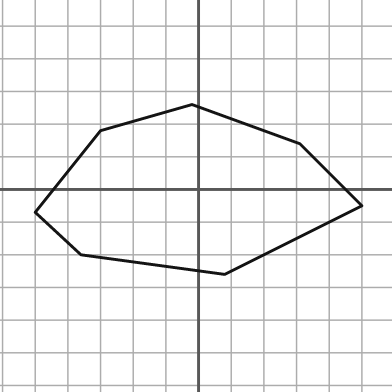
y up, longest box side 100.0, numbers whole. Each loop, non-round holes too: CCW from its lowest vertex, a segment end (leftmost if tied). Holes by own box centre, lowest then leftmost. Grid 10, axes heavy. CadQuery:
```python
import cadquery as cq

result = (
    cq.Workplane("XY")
    .moveTo(8.0, -26.0)
    .lineTo(50.0, -5.0)
    .lineTo(31.0, 14.0)
    .lineTo(-2.0, 26.0)
    .lineTo(-30.0, 18.0)
    .lineTo(-50.0, -7.0)
    .lineTo(-36.0, -20.0)
    .close()
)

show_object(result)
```